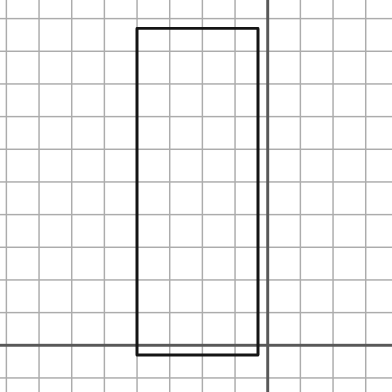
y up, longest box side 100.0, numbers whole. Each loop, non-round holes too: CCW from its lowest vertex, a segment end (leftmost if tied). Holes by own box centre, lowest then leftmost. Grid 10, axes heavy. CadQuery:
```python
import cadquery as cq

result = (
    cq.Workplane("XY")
    .moveTo(-40.0, -3.0)
    .lineTo(-3.0, -3.0)
    .lineTo(-3.0, 97.0)
    .lineTo(-40.0, 97.0)
    .close()
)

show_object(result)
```